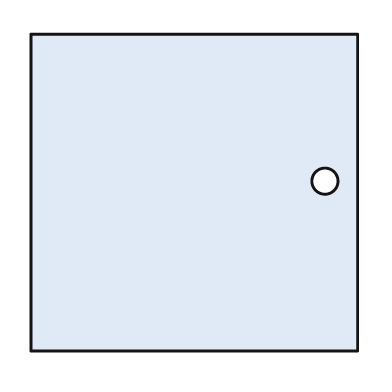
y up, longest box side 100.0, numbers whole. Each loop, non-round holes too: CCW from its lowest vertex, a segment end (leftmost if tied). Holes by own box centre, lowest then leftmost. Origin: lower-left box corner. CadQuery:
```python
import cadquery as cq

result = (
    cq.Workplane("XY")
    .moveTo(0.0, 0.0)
    .lineTo(100.0, 0.0)
    .lineTo(100.0, 97.0)
    .lineTo(0.0, 97.0)
    .close()
    .moveTo(90.0, 52.0)
    .circle(4.0)
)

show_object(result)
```